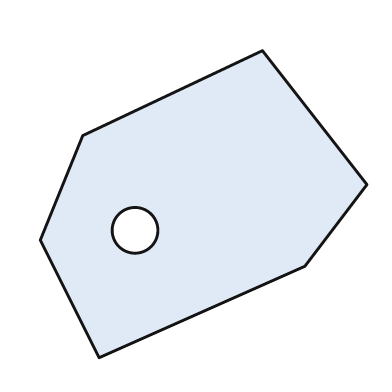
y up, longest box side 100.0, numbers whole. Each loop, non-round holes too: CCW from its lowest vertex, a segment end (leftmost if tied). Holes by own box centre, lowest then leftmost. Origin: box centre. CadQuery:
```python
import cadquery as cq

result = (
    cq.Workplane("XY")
    .moveTo(-32.0, -47.0)
    .lineTo(31.0, -19.0)
    .lineTo(50.0, 6.0)
    .lineTo(18.0, 47.0)
    .lineTo(-37.0, 21.0)
    .lineTo(-50.0, -11.0)
    .close()
    .moveTo(-21.0, -8.0)
    .circle(7.0)
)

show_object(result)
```